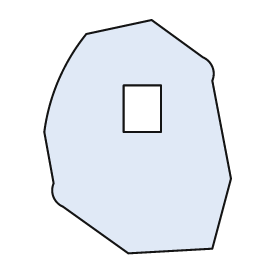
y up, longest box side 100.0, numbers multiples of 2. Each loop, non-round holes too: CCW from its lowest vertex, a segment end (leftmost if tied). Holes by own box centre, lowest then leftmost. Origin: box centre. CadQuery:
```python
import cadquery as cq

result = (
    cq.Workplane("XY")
    .moveTo(-4.0, -50.0)
    .lineTo(32.0, -48.0)
    .lineTo(40.0, -18.0)
    .lineTo(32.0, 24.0)
    .threePointArc((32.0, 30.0), (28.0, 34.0))
    .lineTo(6.0, 50.0)
    .lineTo(-22.0, 44.0)
    .threePointArc((-34.0, 24.0), (-40.0, 2.0))
    .lineTo(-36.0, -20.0)
    .threePointArc((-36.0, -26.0), (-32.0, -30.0))
    .close()
    .moveTo(-6.0, 2.0)
    .lineTo(10.0, 2.0)
    .lineTo(10.0, 22.0)
    .lineTo(-6.0, 22.0)
    .close()
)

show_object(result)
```